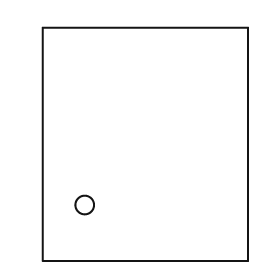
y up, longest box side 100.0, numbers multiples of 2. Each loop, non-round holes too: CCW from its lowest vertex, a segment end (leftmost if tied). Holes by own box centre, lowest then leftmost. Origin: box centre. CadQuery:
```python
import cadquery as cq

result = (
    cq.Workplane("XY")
    .moveTo(-44.0, -50.0)
    .lineTo(44.0, -50.0)
    .lineTo(44.0, 50.0)
    .lineTo(-44.0, 50.0)
    .close()
    .moveTo(-26.0, -26.0)
    .circle(4.0)
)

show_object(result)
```